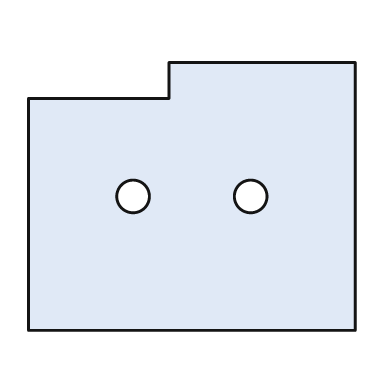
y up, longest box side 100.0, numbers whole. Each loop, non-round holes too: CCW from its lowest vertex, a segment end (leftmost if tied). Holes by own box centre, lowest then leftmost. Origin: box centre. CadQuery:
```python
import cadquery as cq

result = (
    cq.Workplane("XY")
    .moveTo(-50.0, -41.0)
    .lineTo(50.0, -41.0)
    .lineTo(50.0, 41.0)
    .lineTo(-7.0, 41.0)
    .lineTo(-7.0, 30.0)
    .lineTo(-50.0, 30.0)
    .close()
    .moveTo(-18.0, 0.0)
    .circle(5.0)
    .moveTo(18.0, 0.0)
    .circle(5.0)
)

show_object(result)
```